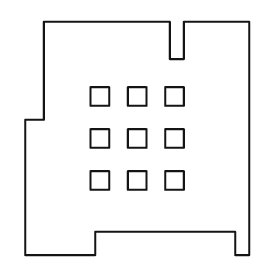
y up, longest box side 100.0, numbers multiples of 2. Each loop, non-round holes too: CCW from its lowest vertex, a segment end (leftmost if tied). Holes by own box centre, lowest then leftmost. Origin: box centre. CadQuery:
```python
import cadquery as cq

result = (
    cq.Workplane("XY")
    .moveTo(-48.0, -50.0)
    .lineTo(-18.0, -50.0)
    .lineTo(-18.0, -40.0)
    .lineTo(42.0, -40.0)
    .lineTo(42.0, -50.0)
    .lineTo(48.0, -50.0)
    .lineTo(48.0, 50.0)
    .lineTo(20.0, 50.0)
    .lineTo(20.0, 34.0)
    .lineTo(14.0, 34.0)
    .lineTo(14.0, 50.0)
    .lineTo(-40.0, 50.0)
    .lineTo(-40.0, 8.0)
    .lineTo(-48.0, 8.0)
    .close()
    .moveTo(-20.0, -22.0)
    .lineTo(-12.0, -22.0)
    .lineTo(-12.0, -14.0)
    .lineTo(-20.0, -14.0)
    .close()
    .moveTo(-4.0, -22.0)
    .lineTo(4.0, -22.0)
    .lineTo(4.0, -14.0)
    .lineTo(-4.0, -14.0)
    .close()
    .moveTo(12.0, -22.0)
    .lineTo(20.0, -22.0)
    .lineTo(20.0, -14.0)
    .lineTo(12.0, -14.0)
    .close()
    .moveTo(-20.0, -4.0)
    .lineTo(-12.0, -4.0)
    .lineTo(-12.0, 4.0)
    .lineTo(-20.0, 4.0)
    .close()
    .moveTo(-4.0, -4.0)
    .lineTo(4.0, -4.0)
    .lineTo(4.0, 4.0)
    .lineTo(-4.0, 4.0)
    .close()
    .moveTo(12.0, -4.0)
    .lineTo(20.0, -4.0)
    .lineTo(20.0, 4.0)
    .lineTo(12.0, 4.0)
    .close()
    .moveTo(-20.0, 14.0)
    .lineTo(-12.0, 14.0)
    .lineTo(-12.0, 22.0)
    .lineTo(-20.0, 22.0)
    .close()
    .moveTo(-4.0, 14.0)
    .lineTo(4.0, 14.0)
    .lineTo(4.0, 22.0)
    .lineTo(-4.0, 22.0)
    .close()
    .moveTo(12.0, 14.0)
    .lineTo(20.0, 14.0)
    .lineTo(20.0, 22.0)
    .lineTo(12.0, 22.0)
    .close()
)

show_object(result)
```